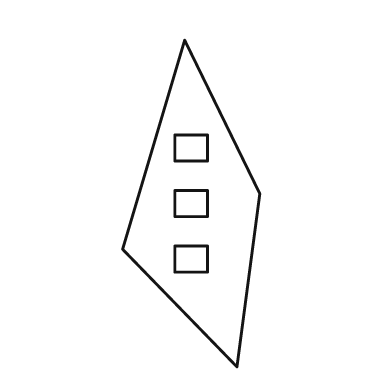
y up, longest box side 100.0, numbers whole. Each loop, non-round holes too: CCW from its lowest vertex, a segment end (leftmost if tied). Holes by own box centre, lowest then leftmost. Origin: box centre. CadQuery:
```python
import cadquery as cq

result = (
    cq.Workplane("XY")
    .moveTo(14.0, -50.0)
    .lineTo(21.0, 3.0)
    .lineTo(-2.0, 50.0)
    .lineTo(-21.0, -14.0)
    .close()
    .moveTo(-5.0, -21.0)
    .lineTo(5.0, -21.0)
    .lineTo(5.0, -13.0)
    .lineTo(-5.0, -13.0)
    .close()
    .moveTo(-5.0, -4.0)
    .lineTo(5.0, -4.0)
    .lineTo(5.0, 4.0)
    .lineTo(-5.0, 4.0)
    .close()
    .moveTo(-5.0, 13.0)
    .lineTo(5.0, 13.0)
    .lineTo(5.0, 21.0)
    .lineTo(-5.0, 21.0)
    .close()
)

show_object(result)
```